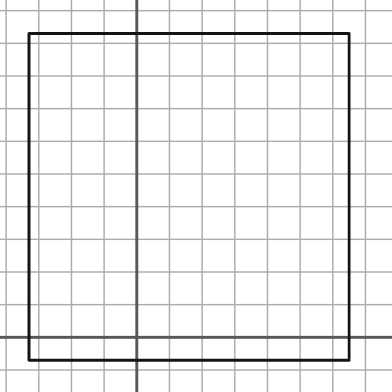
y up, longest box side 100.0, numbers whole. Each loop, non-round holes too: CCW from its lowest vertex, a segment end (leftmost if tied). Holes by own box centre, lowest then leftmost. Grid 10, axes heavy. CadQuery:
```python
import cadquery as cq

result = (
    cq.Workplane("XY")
    .moveTo(-33.0, -7.0)
    .lineTo(65.0, -7.0)
    .lineTo(65.0, 93.0)
    .lineTo(-33.0, 93.0)
    .close()
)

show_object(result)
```